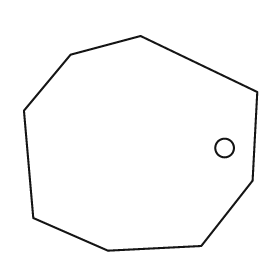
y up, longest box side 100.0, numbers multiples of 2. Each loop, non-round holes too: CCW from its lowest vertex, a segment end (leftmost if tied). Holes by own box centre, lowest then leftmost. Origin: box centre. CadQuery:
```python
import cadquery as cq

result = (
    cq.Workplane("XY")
    .moveTo(-14.0, -46.0)
    .lineTo(26.0, -44.0)
    .lineTo(48.0, -16.0)
    .lineTo(50.0, 22.0)
    .lineTo(0.0, 46.0)
    .lineTo(-30.0, 38.0)
    .lineTo(-50.0, 14.0)
    .lineTo(-46.0, -32.0)
    .close()
    .moveTo(36.0, -2.0)
    .circle(4.0)
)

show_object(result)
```